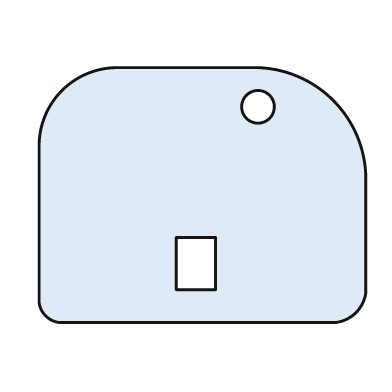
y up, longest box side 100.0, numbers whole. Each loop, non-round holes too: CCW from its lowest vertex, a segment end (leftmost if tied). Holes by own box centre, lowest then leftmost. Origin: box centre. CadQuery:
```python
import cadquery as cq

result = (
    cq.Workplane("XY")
    .moveTo(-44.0, -39.0)
    .lineTo(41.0, -39.0)
    .threePointArc((47.0, -36.0), (50.0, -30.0))
    .lineTo(50.0, 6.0)
    .threePointArc((40.0, 29.0), (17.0, 39.0))
    .lineTo(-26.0, 39.0)
    .threePointArc((-43.0, 32.0), (-50.0, 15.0))
    .lineTo(-50.0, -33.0)
    .threePointArc((-48.0, -37.0), (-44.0, -39.0))
    .close()
    .moveTo(-8.0, -29.0)
    .lineTo(4.0, -29.0)
    .lineTo(4.0, -13.0)
    .lineTo(-8.0, -13.0)
    .close()
    .moveTo(17.0, 27.0)
    .circle(5.0)
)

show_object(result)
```